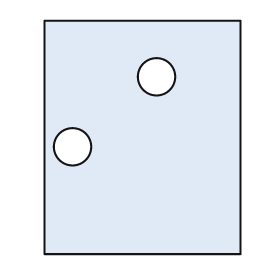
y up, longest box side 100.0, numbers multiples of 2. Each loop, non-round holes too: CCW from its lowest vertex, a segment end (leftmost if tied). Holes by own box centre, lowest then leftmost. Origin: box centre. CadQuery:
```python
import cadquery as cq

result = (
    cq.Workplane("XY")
    .moveTo(-42.0, -50.0)
    .lineTo(42.0, -50.0)
    .lineTo(42.0, 50.0)
    .lineTo(-42.0, 50.0)
    .close()
    .moveTo(-30.0, -4.0)
    .circle(8.0)
    .moveTo(6.0, 26.0)
    .circle(8.0)
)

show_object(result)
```